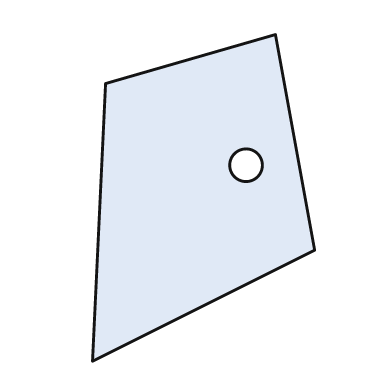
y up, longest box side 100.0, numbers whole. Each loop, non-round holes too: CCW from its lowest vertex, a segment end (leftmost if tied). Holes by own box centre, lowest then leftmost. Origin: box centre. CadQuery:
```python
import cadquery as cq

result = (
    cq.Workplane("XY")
    .moveTo(-34.0, -50.0)
    .lineTo(34.0, -16.0)
    .lineTo(22.0, 50.0)
    .lineTo(-30.0, 35.0)
    .close()
    .moveTo(13.0, 10.0)
    .circle(5.0)
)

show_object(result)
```